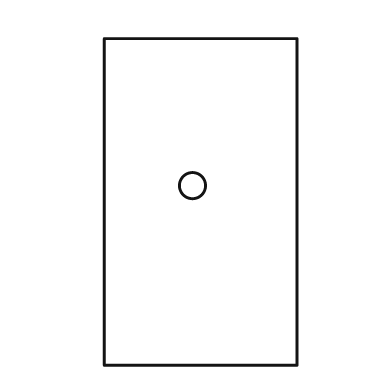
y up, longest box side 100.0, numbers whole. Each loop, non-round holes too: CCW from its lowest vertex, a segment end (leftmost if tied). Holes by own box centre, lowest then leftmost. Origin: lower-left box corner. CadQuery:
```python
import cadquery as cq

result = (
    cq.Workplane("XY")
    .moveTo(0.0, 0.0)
    .lineTo(59.0, 0.0)
    .lineTo(59.0, 100.0)
    .lineTo(0.0, 100.0)
    .close()
    .moveTo(27.0, 55.0)
    .circle(4.0)
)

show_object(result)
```